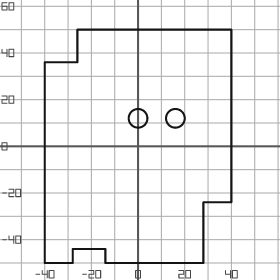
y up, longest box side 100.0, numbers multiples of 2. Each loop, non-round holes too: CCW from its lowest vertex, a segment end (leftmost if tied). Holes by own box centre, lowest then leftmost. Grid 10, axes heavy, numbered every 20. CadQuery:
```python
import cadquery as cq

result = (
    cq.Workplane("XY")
    .moveTo(-40.0, -50.0)
    .lineTo(-28.0, -50.0)
    .lineTo(-28.0, -44.0)
    .lineTo(-14.0, -44.0)
    .lineTo(-14.0, -50.0)
    .lineTo(28.0, -50.0)
    .lineTo(28.0, -24.0)
    .lineTo(40.0, -24.0)
    .lineTo(40.0, 50.0)
    .lineTo(-26.0, 50.0)
    .lineTo(-26.0, 36.0)
    .lineTo(-40.0, 36.0)
    .close()
    .moveTo(0.0, 12.0)
    .circle(4.0)
    .moveTo(16.0, 12.0)
    .circle(4.0)
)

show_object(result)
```